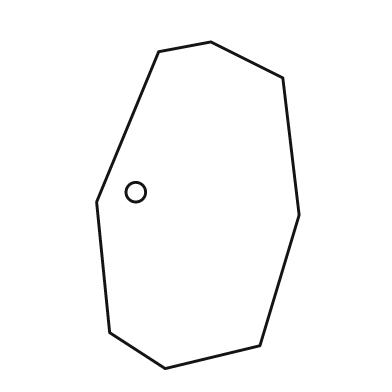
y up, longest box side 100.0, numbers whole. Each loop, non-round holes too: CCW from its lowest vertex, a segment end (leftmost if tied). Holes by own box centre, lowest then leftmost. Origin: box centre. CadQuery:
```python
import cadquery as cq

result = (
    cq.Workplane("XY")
    .moveTo(-10.0, -50.0)
    .lineTo(19.0, -43.0)
    .lineTo(31.0, -3.0)
    .lineTo(26.0, 39.0)
    .lineTo(4.0, 50.0)
    .lineTo(-12.0, 47.0)
    .lineTo(-31.0, 1.0)
    .lineTo(-27.0, -39.0)
    .close()
    .moveTo(-19.0, 4.0)
    .circle(3.0)
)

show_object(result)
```